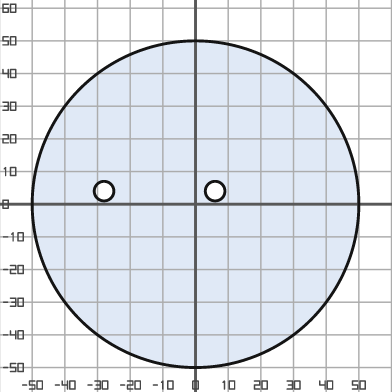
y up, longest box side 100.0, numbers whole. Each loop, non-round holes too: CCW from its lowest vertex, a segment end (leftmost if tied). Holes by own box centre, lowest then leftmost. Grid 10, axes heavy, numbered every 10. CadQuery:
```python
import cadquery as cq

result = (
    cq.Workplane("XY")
    .moveTo(0.0, 0.0)
    .circle(50.0)
    .moveTo(-28.0, 4.0)
    .circle(3.0)
    .moveTo(6.0, 4.0)
    .circle(3.0)
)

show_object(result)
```